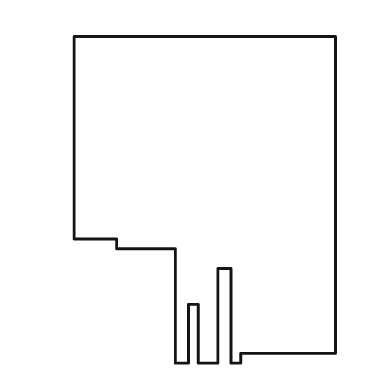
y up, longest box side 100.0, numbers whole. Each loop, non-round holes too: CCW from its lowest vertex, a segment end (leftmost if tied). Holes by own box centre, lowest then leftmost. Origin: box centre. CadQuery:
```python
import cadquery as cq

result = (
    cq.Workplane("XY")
    .moveTo(-9.0, -50.0)
    .lineTo(-5.0, -50.0)
    .lineTo(-5.0, -32.0)
    .lineTo(-2.0, -32.0)
    .lineTo(-2.0, -50.0)
    .lineTo(4.0, -50.0)
    .lineTo(4.0, -21.0)
    .lineTo(8.0, -21.0)
    .lineTo(8.0, -50.0)
    .lineTo(11.0, -50.0)
    .lineTo(11.0, -47.0)
    .lineTo(40.0, -47.0)
    .lineTo(40.0, 50.0)
    .lineTo(-40.0, 50.0)
    .lineTo(-40.0, -12.0)
    .lineTo(-27.0, -12.0)
    .lineTo(-27.0, -15.0)
    .lineTo(-9.0, -15.0)
    .close()
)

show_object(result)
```